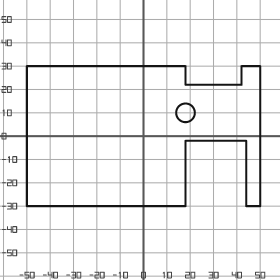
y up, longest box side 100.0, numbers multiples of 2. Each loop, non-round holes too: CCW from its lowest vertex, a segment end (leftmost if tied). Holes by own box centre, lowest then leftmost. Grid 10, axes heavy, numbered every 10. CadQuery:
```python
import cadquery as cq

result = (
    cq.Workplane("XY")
    .moveTo(-50.0, -30.0)
    .lineTo(18.0, -30.0)
    .lineTo(18.0, -2.0)
    .lineTo(44.0, -2.0)
    .lineTo(44.0, -30.0)
    .lineTo(50.0, -30.0)
    .lineTo(50.0, 30.0)
    .lineTo(42.0, 30.0)
    .lineTo(42.0, 22.0)
    .lineTo(18.0, 22.0)
    .lineTo(18.0, 30.0)
    .lineTo(-50.0, 30.0)
    .close()
    .moveTo(18.0, 10.0)
    .circle(4.0)
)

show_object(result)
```